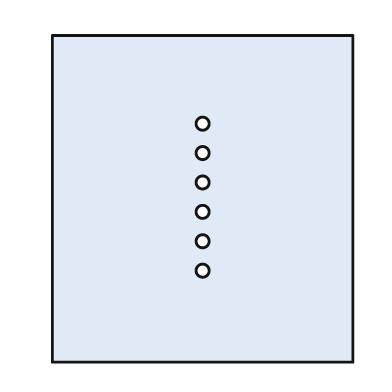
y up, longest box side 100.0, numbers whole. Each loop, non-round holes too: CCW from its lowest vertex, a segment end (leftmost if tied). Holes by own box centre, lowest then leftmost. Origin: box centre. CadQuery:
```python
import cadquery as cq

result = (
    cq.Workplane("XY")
    .moveTo(-46.0, -50.0)
    .lineTo(46.0, -50.0)
    .lineTo(46.0, 50.0)
    .lineTo(-46.0, 50.0)
    .close()
    .moveTo(0.0, -22.0)
    .circle(2.0)
    .moveTo(0.0, -13.0)
    .circle(2.0)
    .moveTo(0.0, -4.0)
    .circle(2.0)
    .moveTo(0.0, 5.0)
    .circle(2.0)
    .moveTo(0.0, 14.0)
    .circle(2.0)
    .moveTo(0.0, 23.0)
    .circle(2.0)
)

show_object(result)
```